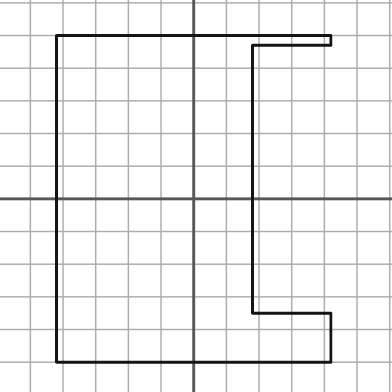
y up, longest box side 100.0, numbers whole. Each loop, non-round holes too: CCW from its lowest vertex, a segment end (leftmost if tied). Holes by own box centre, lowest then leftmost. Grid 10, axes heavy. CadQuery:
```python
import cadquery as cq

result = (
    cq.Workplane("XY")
    .moveTo(-42.0, -50.0)
    .lineTo(42.0, -50.0)
    .lineTo(42.0, -35.0)
    .lineTo(18.0, -35.0)
    .lineTo(18.0, 47.0)
    .lineTo(42.0, 47.0)
    .lineTo(42.0, 50.0)
    .lineTo(-42.0, 50.0)
    .close()
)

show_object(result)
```